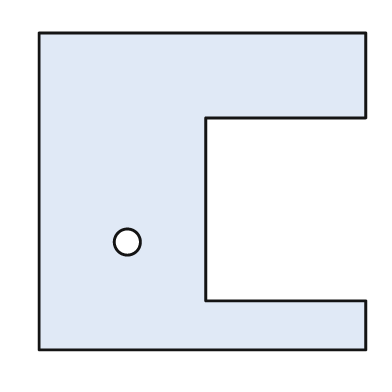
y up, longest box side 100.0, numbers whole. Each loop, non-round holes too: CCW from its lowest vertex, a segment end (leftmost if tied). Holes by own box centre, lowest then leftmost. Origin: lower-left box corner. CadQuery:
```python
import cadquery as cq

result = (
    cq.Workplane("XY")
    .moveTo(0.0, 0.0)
    .lineTo(100.0, 0.0)
    .lineTo(100.0, 15.0)
    .lineTo(51.0, 15.0)
    .lineTo(51.0, 71.0)
    .lineTo(100.0, 71.0)
    .lineTo(100.0, 97.0)
    .lineTo(0.0, 97.0)
    .close()
    .moveTo(27.0, 33.0)
    .circle(4.0)
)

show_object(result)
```